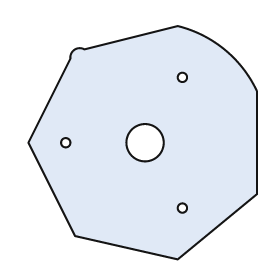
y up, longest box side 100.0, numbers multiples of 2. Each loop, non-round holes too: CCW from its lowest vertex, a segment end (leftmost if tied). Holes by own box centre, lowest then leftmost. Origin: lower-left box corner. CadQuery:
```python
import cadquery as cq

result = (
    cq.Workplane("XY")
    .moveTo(64.0, 0.0)
    .lineTo(98.0, 28.0)
    .lineTo(98.0, 72.0)
    .threePointArc((84.0, 90.0), (64.0, 100.0))
    .lineTo(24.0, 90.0)
    .threePointArc((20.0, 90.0), (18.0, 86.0))
    .lineTo(0.0, 50.0)
    .lineTo(20.0, 10.0)
    .close()
    .moveTo(66.0, 22.0)
    .circle(2.0)
    .moveTo(16.0, 50.0)
    .circle(2.0)
    .moveTo(50.0, 50.0)
    .circle(8.0)
    .moveTo(66.0, 78.0)
    .circle(2.0)
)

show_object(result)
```